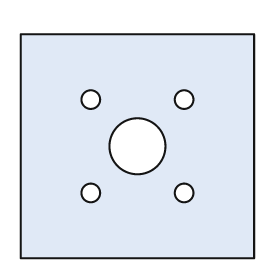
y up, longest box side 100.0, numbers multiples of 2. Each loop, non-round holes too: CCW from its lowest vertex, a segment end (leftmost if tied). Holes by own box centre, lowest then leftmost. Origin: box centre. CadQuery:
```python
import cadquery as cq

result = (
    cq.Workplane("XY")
    .moveTo(-50.0, -48.0)
    .lineTo(50.0, -48.0)
    .lineTo(50.0, 48.0)
    .lineTo(-50.0, 48.0)
    .close()
    .moveTo(-20.0, -20.0)
    .circle(4.0)
    .moveTo(20.0, -20.0)
    .circle(4.0)
    .moveTo(0.0, 0.0)
    .circle(12.0)
    .moveTo(-20.0, 20.0)
    .circle(4.0)
    .moveTo(20.0, 20.0)
    .circle(4.0)
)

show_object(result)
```